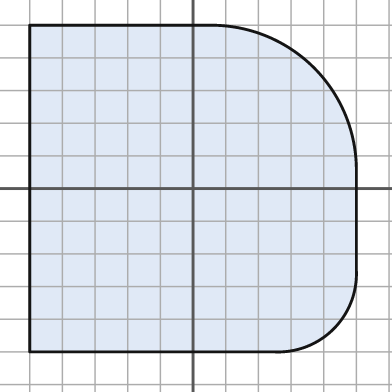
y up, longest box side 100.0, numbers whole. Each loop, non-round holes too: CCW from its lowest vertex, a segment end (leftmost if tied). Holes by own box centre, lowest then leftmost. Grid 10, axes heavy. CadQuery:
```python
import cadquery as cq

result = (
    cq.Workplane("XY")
    .moveTo(-50.0, -50.0)
    .lineTo(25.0, -50.0)
    .threePointArc((43.0, -43.0), (50.0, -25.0))
    .lineTo(50.0, 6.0)
    .threePointArc((37.0, 37.0), (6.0, 50.0))
    .lineTo(-50.0, 50.0)
    .close()
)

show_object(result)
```